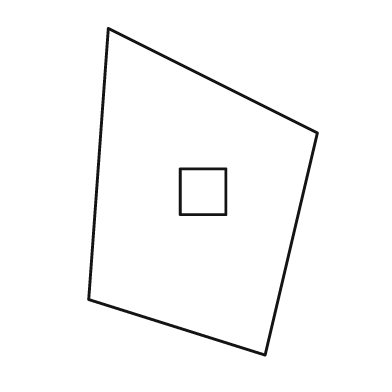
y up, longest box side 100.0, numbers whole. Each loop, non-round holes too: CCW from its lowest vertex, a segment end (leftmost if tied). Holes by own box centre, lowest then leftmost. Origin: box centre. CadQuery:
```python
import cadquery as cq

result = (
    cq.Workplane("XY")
    .moveTo(19.0, -50.0)
    .lineTo(35.0, 18.0)
    .lineTo(-29.0, 50.0)
    .lineTo(-35.0, -33.0)
    .close()
    .moveTo(-7.0, -7.0)
    .lineTo(7.0, -7.0)
    .lineTo(7.0, 7.0)
    .lineTo(-7.0, 7.0)
    .close()
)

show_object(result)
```